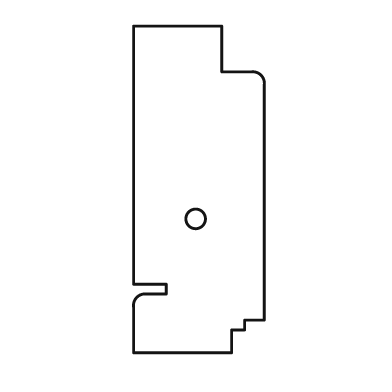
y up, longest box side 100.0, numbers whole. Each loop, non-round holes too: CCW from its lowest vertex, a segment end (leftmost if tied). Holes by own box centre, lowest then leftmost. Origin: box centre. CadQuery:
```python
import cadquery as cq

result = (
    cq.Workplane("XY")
    .moveTo(-20.0, -50.0)
    .lineTo(10.0, -50.0)
    .lineTo(10.0, -43.0)
    .lineTo(14.0, -43.0)
    .lineTo(14.0, -40.0)
    .lineTo(20.0, -40.0)
    .lineTo(20.0, 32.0)
    .threePointArc((19.0, 35.0), (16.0, 36.0))
    .lineTo(7.0, 36.0)
    .lineTo(7.0, 50.0)
    .lineTo(-20.0, 50.0)
    .lineTo(-20.0, -29.0)
    .lineTo(-10.0, -29.0)
    .lineTo(-10.0, -32.0)
    .lineTo(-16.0, -32.0)
    .threePointArc((-19.0, -33.0), (-20.0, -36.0))
    .close()
    .moveTo(-1.0, -9.0)
    .circle(3.0)
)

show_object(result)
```